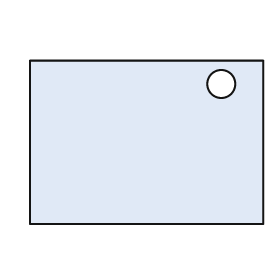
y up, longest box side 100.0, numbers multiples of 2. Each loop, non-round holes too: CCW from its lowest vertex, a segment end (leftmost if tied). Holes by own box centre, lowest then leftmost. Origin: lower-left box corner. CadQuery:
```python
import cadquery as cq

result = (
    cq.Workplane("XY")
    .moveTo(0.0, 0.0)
    .lineTo(100.0, 0.0)
    .lineTo(100.0, 70.0)
    .lineTo(0.0, 70.0)
    .close()
    .moveTo(82.0, 60.0)
    .circle(6.0)
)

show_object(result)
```